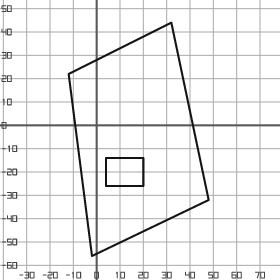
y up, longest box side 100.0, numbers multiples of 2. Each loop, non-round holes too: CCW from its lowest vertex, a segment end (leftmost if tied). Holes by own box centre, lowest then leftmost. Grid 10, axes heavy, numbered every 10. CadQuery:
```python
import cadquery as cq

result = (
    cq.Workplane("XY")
    .moveTo(-2.0, -56.0)
    .lineTo(48.0, -32.0)
    .lineTo(32.0, 44.0)
    .lineTo(-12.0, 22.0)
    .close()
    .moveTo(4.0, -26.0)
    .lineTo(20.0, -26.0)
    .lineTo(20.0, -14.0)
    .lineTo(4.0, -14.0)
    .close()
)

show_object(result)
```